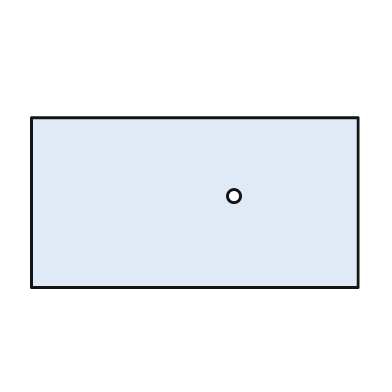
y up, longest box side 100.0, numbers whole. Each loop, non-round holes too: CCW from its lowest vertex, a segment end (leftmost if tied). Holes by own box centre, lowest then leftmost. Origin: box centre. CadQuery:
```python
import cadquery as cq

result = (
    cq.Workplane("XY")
    .moveTo(-50.0, -26.0)
    .lineTo(50.0, -26.0)
    .lineTo(50.0, 26.0)
    .lineTo(-50.0, 26.0)
    .close()
    .moveTo(12.0, 2.0)
    .circle(2.0)
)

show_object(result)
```